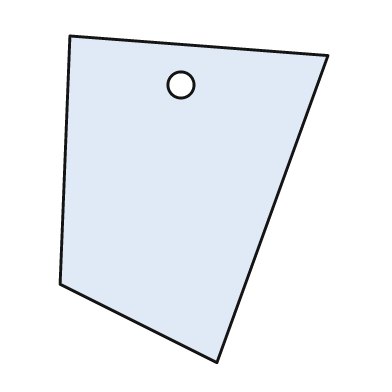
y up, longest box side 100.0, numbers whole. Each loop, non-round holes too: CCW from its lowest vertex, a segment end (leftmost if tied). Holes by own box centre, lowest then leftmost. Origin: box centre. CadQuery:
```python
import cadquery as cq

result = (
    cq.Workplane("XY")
    .moveTo(7.0, -50.0)
    .lineTo(41.0, 44.0)
    .lineTo(-38.0, 50.0)
    .lineTo(-41.0, -26.0)
    .close()
    .moveTo(-4.0, 35.0)
    .circle(4.0)
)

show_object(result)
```